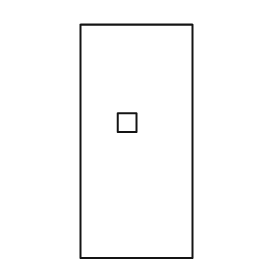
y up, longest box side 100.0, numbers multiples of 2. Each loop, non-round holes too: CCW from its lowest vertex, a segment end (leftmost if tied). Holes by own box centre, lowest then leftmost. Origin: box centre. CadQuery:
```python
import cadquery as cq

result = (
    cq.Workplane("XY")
    .moveTo(-24.0, -50.0)
    .lineTo(24.0, -50.0)
    .lineTo(24.0, 50.0)
    .lineTo(-24.0, 50.0)
    .close()
    .moveTo(-8.0, 4.0)
    .lineTo(0.0, 4.0)
    .lineTo(0.0, 12.0)
    .lineTo(-8.0, 12.0)
    .close()
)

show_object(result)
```